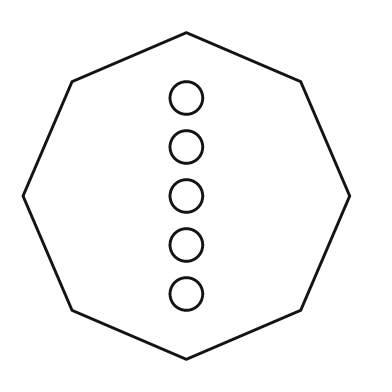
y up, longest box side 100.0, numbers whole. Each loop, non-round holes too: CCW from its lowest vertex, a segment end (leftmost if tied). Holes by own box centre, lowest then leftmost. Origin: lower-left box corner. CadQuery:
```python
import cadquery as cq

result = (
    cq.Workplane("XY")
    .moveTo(50.0, 0.0)
    .lineTo(85.0, 15.0)
    .lineTo(100.0, 50.0)
    .lineTo(85.0, 85.0)
    .lineTo(50.0, 100.0)
    .lineTo(15.0, 85.0)
    .lineTo(0.0, 50.0)
    .lineTo(15.0, 15.0)
    .close()
    .moveTo(50.0, 20.0)
    .circle(5.0)
    .moveTo(50.0, 35.0)
    .circle(5.0)
    .moveTo(50.0, 50.0)
    .circle(5.0)
    .moveTo(50.0, 65.0)
    .circle(5.0)
    .moveTo(50.0, 80.0)
    .circle(5.0)
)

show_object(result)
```